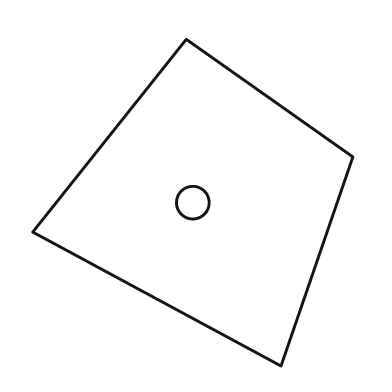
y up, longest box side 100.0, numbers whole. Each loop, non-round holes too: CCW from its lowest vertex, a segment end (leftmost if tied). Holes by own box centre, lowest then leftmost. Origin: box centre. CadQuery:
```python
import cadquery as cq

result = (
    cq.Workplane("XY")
    .moveTo(27.0, -50.0)
    .lineTo(49.0, 14.0)
    .lineTo(-2.0, 50.0)
    .lineTo(-49.0, -9.0)
    .close()
    .moveTo(0.0, 0.0)
    .circle(5.0)
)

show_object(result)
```